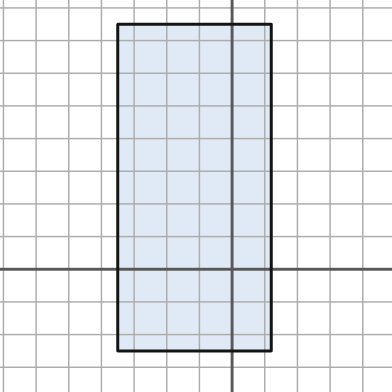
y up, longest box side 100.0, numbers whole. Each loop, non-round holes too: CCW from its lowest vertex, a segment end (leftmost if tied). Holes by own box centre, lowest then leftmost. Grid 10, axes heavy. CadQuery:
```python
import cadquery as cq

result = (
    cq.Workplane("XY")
    .moveTo(-35.0, -25.0)
    .lineTo(12.0, -25.0)
    .lineTo(12.0, 75.0)
    .lineTo(-35.0, 75.0)
    .close()
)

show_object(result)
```